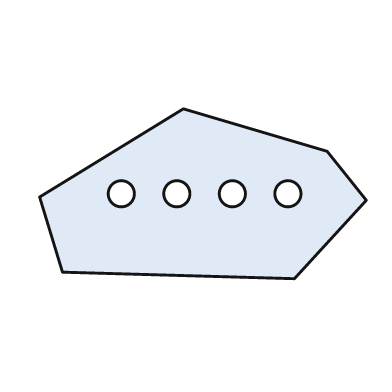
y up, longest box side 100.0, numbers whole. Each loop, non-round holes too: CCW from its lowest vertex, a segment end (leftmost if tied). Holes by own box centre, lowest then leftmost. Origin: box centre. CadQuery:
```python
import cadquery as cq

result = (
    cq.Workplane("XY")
    .moveTo(28.0, -26.0)
    .lineTo(50.0, -2.0)
    .lineTo(38.0, 13.0)
    .lineTo(-6.0, 26.0)
    .lineTo(-50.0, -1.0)
    .lineTo(-43.0, -24.0)
    .close()
    .moveTo(-25.0, 0.0)
    .circle(4.0)
    .moveTo(-8.0, 0.0)
    .circle(4.0)
    .moveTo(9.0, 0.0)
    .circle(4.0)
    .moveTo(26.0, 0.0)
    .circle(4.0)
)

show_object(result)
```